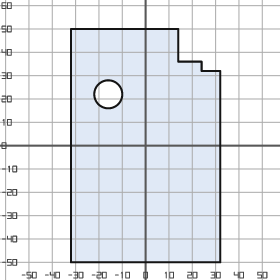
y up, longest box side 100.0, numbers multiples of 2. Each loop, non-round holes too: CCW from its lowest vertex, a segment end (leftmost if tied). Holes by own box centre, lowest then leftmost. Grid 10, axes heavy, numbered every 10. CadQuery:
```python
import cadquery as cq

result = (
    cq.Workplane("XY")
    .moveTo(-32.0, -50.0)
    .lineTo(32.0, -50.0)
    .lineTo(32.0, 32.0)
    .lineTo(24.0, 32.0)
    .lineTo(24.0, 36.0)
    .lineTo(14.0, 36.0)
    .lineTo(14.0, 50.0)
    .lineTo(-32.0, 50.0)
    .close()
    .moveTo(-16.0, 22.0)
    .circle(6.0)
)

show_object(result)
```